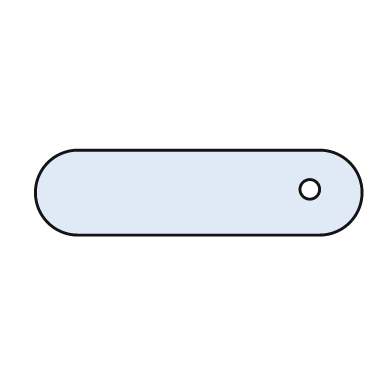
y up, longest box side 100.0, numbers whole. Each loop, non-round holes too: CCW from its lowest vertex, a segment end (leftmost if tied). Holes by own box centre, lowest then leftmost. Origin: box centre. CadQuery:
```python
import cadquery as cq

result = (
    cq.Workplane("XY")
    .moveTo(-37.0, -13.0)
    .lineTo(37.0, -13.0)
    .threePointArc((50.0, 0.0), (37.0, 13.0))
    .lineTo(-37.0, 13.0)
    .threePointArc((-50.0, 0.0), (-37.0, -13.0))
    .close()
    .moveTo(34.0, 1.0)
    .circle(3.0)
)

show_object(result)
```